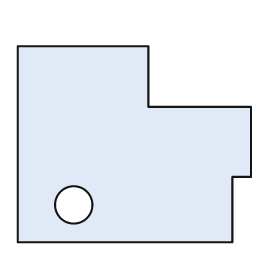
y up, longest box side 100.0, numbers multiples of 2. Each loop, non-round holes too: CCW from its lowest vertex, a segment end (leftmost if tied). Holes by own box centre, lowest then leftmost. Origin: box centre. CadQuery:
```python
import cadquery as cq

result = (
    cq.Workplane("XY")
    .moveTo(-50.0, -42.0)
    .lineTo(42.0, -42.0)
    .lineTo(42.0, -14.0)
    .lineTo(50.0, -14.0)
    .lineTo(50.0, 16.0)
    .lineTo(6.0, 16.0)
    .lineTo(6.0, 42.0)
    .lineTo(-50.0, 42.0)
    .close()
    .moveTo(-26.0, -26.0)
    .circle(8.0)
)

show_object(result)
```